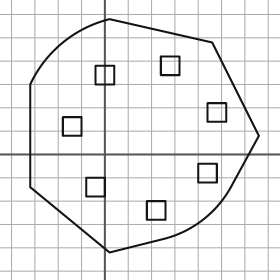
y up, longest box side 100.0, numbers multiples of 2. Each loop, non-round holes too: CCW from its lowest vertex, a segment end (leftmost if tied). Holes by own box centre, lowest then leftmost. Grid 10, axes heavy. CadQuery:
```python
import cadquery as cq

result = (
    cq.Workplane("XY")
    .moveTo(2.0, -42.0)
    .lineTo(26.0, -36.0)
    .threePointArc((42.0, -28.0), (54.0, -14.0))
    .lineTo(66.0, 8.0)
    .lineTo(46.0, 48.0)
    .lineTo(2.0, 58.0)
    .threePointArc((-18.0, 48.0), (-32.0, 30.0))
    .lineTo(-32.0, -14.0)
    .close()
    .moveTo(18.0, -28.0)
    .lineTo(26.0, -28.0)
    .lineTo(26.0, -20.0)
    .lineTo(18.0, -20.0)
    .close()
    .moveTo(-8.0, -18.0)
    .lineTo(0.0, -18.0)
    .lineTo(0.0, -10.0)
    .lineTo(-8.0, -10.0)
    .close()
    .moveTo(40.0, -12.0)
    .lineTo(48.0, -12.0)
    .lineTo(48.0, -4.0)
    .lineTo(40.0, -4.0)
    .close()
    .moveTo(-18.0, 8.0)
    .lineTo(-10.0, 8.0)
    .lineTo(-10.0, 16.0)
    .lineTo(-18.0, 16.0)
    .close()
    .moveTo(44.0, 14.0)
    .lineTo(52.0, 14.0)
    .lineTo(52.0, 22.0)
    .lineTo(44.0, 22.0)
    .close()
    .moveTo(-4.0, 30.0)
    .lineTo(4.0, 30.0)
    .lineTo(4.0, 38.0)
    .lineTo(-4.0, 38.0)
    .close()
    .moveTo(24.0, 34.0)
    .lineTo(32.0, 34.0)
    .lineTo(32.0, 42.0)
    .lineTo(24.0, 42.0)
    .close()
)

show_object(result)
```